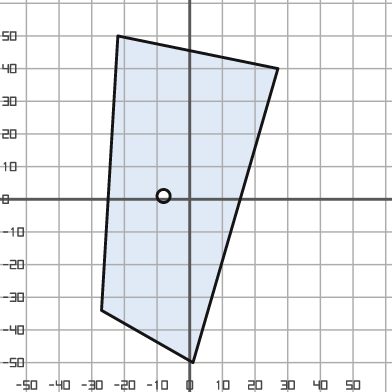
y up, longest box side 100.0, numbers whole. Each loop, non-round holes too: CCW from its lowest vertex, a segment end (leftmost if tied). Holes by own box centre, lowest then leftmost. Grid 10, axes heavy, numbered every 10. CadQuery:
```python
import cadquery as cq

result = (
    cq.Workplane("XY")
    .moveTo(1.0, -50.0)
    .lineTo(27.0, 40.0)
    .lineTo(-22.0, 50.0)
    .lineTo(-27.0, -34.0)
    .close()
    .moveTo(-8.0, 1.0)
    .circle(2.0)
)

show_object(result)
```